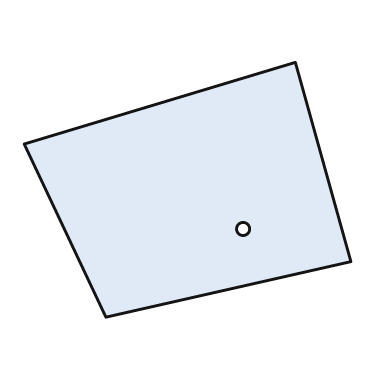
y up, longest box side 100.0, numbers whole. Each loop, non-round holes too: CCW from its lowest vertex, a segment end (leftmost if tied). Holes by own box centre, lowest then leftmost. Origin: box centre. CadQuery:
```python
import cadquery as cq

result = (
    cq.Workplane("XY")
    .moveTo(-25.0, -39.0)
    .lineTo(50.0, -22.0)
    .lineTo(33.0, 39.0)
    .lineTo(-50.0, 14.0)
    .close()
    .moveTo(17.0, -12.0)
    .circle(2.0)
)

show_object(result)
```